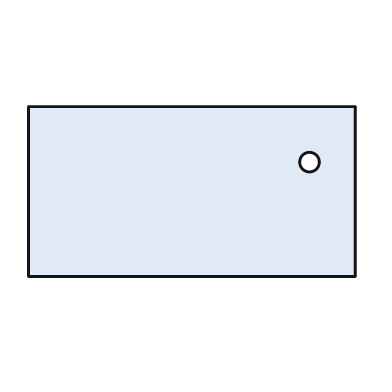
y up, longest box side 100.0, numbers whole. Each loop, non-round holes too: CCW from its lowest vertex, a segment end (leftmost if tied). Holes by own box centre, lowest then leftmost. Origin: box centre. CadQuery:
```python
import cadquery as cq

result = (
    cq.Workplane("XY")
    .moveTo(-50.0, -26.0)
    .lineTo(50.0, -26.0)
    .lineTo(50.0, 26.0)
    .lineTo(-50.0, 26.0)
    .close()
    .moveTo(36.0, 9.0)
    .circle(3.0)
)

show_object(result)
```